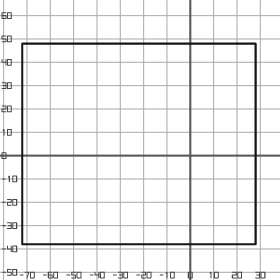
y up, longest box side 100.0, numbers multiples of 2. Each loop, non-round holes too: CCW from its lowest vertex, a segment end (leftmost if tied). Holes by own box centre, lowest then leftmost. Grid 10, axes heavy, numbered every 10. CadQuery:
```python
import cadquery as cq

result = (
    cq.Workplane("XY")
    .moveTo(-72.0, -38.0)
    .lineTo(28.0, -38.0)
    .lineTo(28.0, 48.0)
    .lineTo(-72.0, 48.0)
    .close()
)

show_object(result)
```